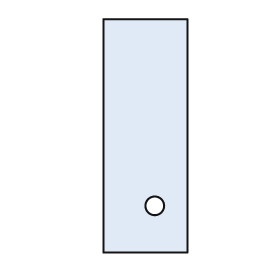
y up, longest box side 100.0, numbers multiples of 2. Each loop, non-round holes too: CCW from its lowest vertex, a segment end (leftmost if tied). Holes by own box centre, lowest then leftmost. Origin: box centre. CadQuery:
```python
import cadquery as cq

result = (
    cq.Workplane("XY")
    .moveTo(-18.0, -50.0)
    .lineTo(18.0, -50.0)
    .lineTo(18.0, 50.0)
    .lineTo(-18.0, 50.0)
    .close()
    .moveTo(4.0, -30.0)
    .circle(4.0)
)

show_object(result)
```